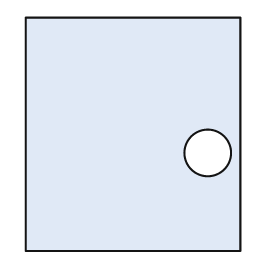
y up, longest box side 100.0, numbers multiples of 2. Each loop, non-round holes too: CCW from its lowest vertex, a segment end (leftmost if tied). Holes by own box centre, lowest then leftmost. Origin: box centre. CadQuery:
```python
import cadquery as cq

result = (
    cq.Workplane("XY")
    .moveTo(-46.0, -50.0)
    .lineTo(46.0, -50.0)
    .lineTo(46.0, 50.0)
    .lineTo(-46.0, 50.0)
    .close()
    .moveTo(32.0, -8.0)
    .circle(10.0)
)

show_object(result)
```